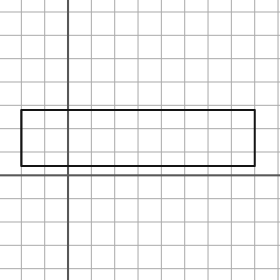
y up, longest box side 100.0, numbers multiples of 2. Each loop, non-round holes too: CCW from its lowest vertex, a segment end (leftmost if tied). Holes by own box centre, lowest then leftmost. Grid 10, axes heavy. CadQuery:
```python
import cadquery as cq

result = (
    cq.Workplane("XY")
    .moveTo(-20.0, 4.0)
    .lineTo(80.0, 4.0)
    .lineTo(80.0, 28.0)
    .lineTo(-20.0, 28.0)
    .close()
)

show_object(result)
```